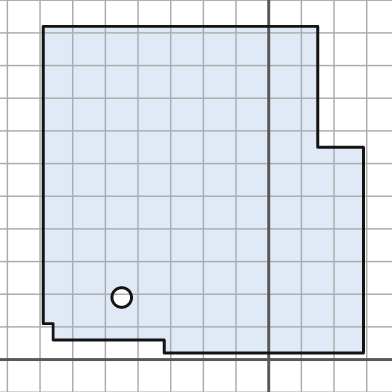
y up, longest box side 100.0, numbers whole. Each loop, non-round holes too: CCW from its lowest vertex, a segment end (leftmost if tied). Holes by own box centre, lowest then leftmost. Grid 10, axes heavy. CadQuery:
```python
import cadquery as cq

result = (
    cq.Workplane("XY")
    .moveTo(-32.0, 2.0)
    .lineTo(29.0, 2.0)
    .lineTo(29.0, 65.0)
    .lineTo(15.0, 65.0)
    .lineTo(15.0, 102.0)
    .lineTo(-69.0, 102.0)
    .lineTo(-69.0, 11.0)
    .lineTo(-66.0, 11.0)
    .lineTo(-66.0, 6.0)
    .lineTo(-32.0, 6.0)
    .close()
    .moveTo(-45.0, 19.0)
    .circle(3.0)
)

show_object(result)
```